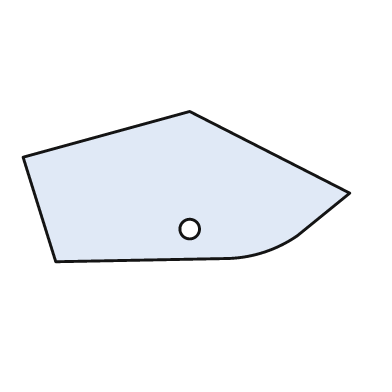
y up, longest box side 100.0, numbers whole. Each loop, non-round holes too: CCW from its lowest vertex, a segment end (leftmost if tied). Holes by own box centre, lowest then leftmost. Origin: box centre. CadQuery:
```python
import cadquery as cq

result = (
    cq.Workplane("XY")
    .moveTo(-40.0, -23.0)
    .lineTo(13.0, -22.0)
    .threePointArc((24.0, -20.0), (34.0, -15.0))
    .lineTo(50.0, -2.0)
    .lineTo(1.0, 23.0)
    .lineTo(-50.0, 9.0)
    .close()
    .moveTo(1.0, -13.0)
    .circle(3.0)
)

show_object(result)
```